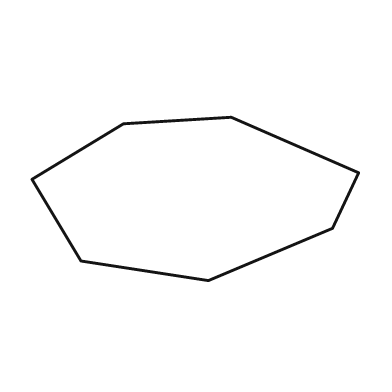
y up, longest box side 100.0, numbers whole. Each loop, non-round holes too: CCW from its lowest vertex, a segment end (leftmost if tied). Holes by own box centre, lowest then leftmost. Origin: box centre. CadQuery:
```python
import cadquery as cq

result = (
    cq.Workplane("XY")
    .moveTo(4.0, -25.0)
    .lineTo(42.0, -9.0)
    .lineTo(50.0, 8.0)
    .lineTo(11.0, 25.0)
    .lineTo(-22.0, 23.0)
    .lineTo(-50.0, 6.0)
    .lineTo(-35.0, -19.0)
    .close()
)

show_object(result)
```